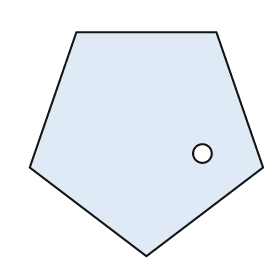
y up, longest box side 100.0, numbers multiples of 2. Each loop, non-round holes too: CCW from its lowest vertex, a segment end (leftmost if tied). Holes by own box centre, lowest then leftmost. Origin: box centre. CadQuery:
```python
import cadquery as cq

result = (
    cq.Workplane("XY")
    .moveTo(0.0, -48.0)
    .lineTo(50.0, -10.0)
    .lineTo(30.0, 48.0)
    .lineTo(-30.0, 48.0)
    .lineTo(-50.0, -10.0)
    .close()
    .moveTo(24.0, -4.0)
    .circle(4.0)
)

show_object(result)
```